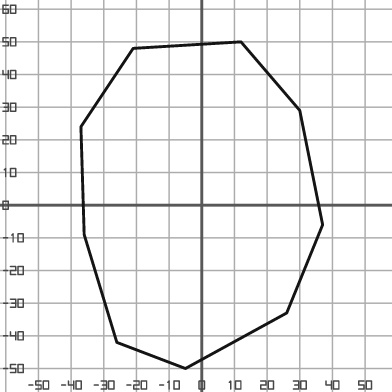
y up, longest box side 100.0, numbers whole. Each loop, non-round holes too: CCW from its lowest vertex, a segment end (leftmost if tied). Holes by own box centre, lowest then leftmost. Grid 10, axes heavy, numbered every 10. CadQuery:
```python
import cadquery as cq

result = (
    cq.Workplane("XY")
    .moveTo(-5.0, -50.0)
    .lineTo(26.0, -33.0)
    .lineTo(37.0, -6.0)
    .lineTo(30.0, 29.0)
    .lineTo(12.0, 50.0)
    .lineTo(-21.0, 48.0)
    .lineTo(-37.0, 24.0)
    .lineTo(-36.0, -9.0)
    .lineTo(-26.0, -42.0)
    .close()
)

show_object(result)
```